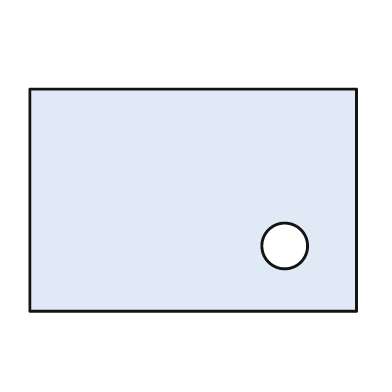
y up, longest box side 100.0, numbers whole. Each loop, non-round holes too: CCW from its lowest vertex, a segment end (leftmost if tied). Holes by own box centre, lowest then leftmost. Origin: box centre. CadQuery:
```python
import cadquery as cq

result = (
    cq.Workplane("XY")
    .moveTo(-50.0, -34.0)
    .lineTo(50.0, -34.0)
    .lineTo(50.0, 34.0)
    .lineTo(-50.0, 34.0)
    .close()
    .moveTo(28.0, -14.0)
    .circle(7.0)
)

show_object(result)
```